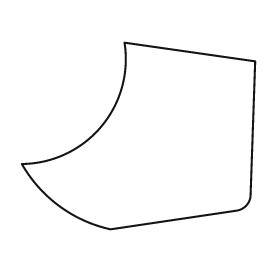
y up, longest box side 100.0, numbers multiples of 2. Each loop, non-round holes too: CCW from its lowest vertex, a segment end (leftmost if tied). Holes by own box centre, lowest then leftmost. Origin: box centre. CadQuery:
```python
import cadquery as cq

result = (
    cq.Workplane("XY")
    .moveTo(-12.0, -40.0)
    .lineTo(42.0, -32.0)
    .threePointArc((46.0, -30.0), (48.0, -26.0))
    .lineTo(50.0, 32.0)
    .lineTo(-6.0, 40.0)
    .threePointArc((-16.0, 4.0), (-50.0, -12.0))
    .threePointArc((-34.0, -30.0), (-12.0, -40.0))
    .close()
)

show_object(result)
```